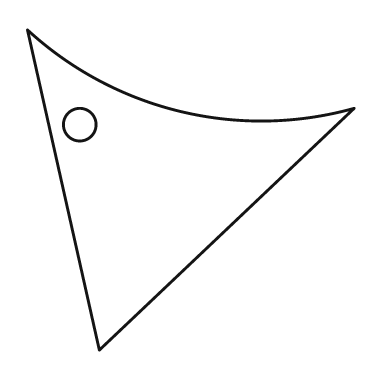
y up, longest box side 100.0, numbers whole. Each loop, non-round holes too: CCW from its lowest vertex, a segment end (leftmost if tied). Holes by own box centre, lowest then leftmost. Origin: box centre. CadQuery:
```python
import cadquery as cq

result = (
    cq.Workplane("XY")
    .moveTo(-28.0, -49.0)
    .lineTo(50.0, 25.0)
    .threePointArc((-3.0, 24.0), (-50.0, 49.0))
    .close()
    .moveTo(-34.0, 20.0)
    .circle(5.0)
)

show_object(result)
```